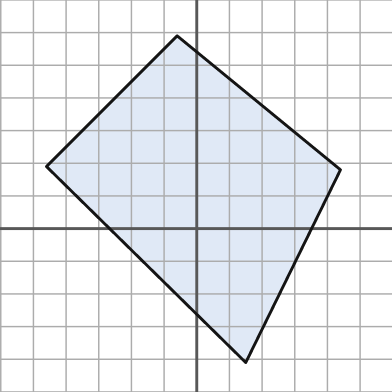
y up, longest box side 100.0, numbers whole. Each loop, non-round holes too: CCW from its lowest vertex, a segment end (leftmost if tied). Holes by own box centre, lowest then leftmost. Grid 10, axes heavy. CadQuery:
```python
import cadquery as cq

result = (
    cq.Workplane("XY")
    .moveTo(15.0, -41.0)
    .lineTo(44.0, 18.0)
    .lineTo(-6.0, 59.0)
    .lineTo(-46.0, 19.0)
    .close()
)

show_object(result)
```